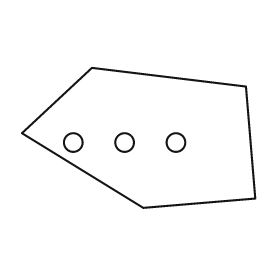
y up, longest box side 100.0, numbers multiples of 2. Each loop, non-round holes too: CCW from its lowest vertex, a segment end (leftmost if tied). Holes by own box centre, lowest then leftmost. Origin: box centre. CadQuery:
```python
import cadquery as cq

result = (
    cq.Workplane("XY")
    .moveTo(2.0, -30.0)
    .lineTo(50.0, -26.0)
    .lineTo(46.0, 22.0)
    .lineTo(-20.0, 30.0)
    .lineTo(-50.0, 2.0)
    .close()
    .moveTo(-28.0, -2.0)
    .circle(4.0)
    .moveTo(-6.0, -2.0)
    .circle(4.0)
    .moveTo(16.0, -2.0)
    .circle(4.0)
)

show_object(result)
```